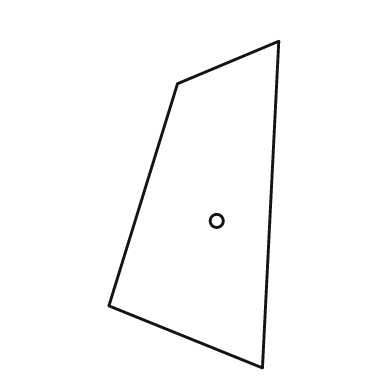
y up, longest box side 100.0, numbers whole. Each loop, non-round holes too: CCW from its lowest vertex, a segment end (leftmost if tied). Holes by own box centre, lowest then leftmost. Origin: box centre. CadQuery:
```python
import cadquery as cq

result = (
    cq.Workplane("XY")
    .moveTo(21.0, -50.0)
    .lineTo(26.0, 50.0)
    .lineTo(-5.0, 37.0)
    .lineTo(-26.0, -31.0)
    .close()
    .moveTo(7.0, -5.0)
    .circle(2.0)
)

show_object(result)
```